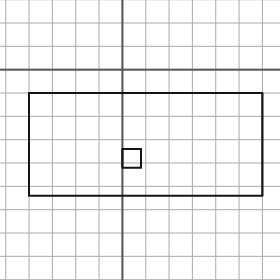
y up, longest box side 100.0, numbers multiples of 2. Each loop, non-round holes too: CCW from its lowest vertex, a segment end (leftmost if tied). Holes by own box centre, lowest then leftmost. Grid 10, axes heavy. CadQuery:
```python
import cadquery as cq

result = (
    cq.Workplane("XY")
    .moveTo(-40.0, -54.0)
    .lineTo(60.0, -54.0)
    .lineTo(60.0, -10.0)
    .lineTo(-40.0, -10.0)
    .close()
    .moveTo(0.0, -42.0)
    .lineTo(8.0, -42.0)
    .lineTo(8.0, -34.0)
    .lineTo(0.0, -34.0)
    .close()
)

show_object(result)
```